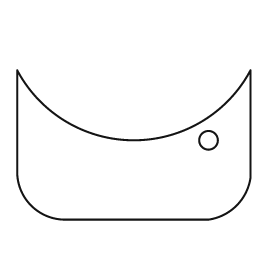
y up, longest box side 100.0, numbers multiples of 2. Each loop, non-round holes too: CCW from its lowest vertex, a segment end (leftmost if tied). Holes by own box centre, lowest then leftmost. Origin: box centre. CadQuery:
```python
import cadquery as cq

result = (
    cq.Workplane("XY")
    .moveTo(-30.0, -32.0)
    .lineTo(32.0, -32.0)
    .threePointArc((44.0, -26.0), (50.0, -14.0))
    .lineTo(50.0, 32.0)
    .threePointArc((0.0, 2.0), (-50.0, 32.0))
    .lineTo(-50.0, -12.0)
    .threePointArc((-44.0, -26.0), (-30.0, -32.0))
    .close()
    .moveTo(32.0, 2.0)
    .circle(4.0)
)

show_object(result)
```